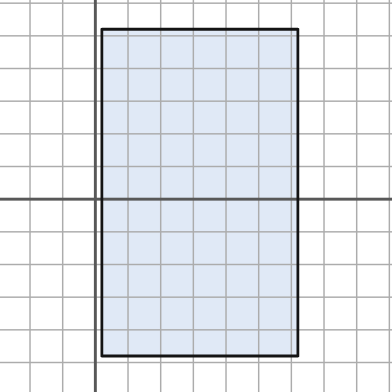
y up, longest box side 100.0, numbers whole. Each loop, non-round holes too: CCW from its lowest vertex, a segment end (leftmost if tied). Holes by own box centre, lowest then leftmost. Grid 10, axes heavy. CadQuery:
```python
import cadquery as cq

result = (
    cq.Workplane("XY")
    .moveTo(2.0, -48.0)
    .lineTo(62.0, -48.0)
    .lineTo(62.0, 52.0)
    .lineTo(2.0, 52.0)
    .close()
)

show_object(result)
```